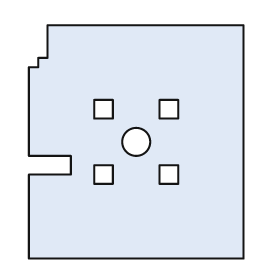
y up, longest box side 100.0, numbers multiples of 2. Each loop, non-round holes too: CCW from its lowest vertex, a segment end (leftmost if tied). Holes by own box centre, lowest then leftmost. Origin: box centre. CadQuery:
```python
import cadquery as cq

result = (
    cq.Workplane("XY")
    .moveTo(-46.0, -50.0)
    .lineTo(46.0, -50.0)
    .lineTo(46.0, 50.0)
    .lineTo(-38.0, 50.0)
    .lineTo(-38.0, 36.0)
    .lineTo(-42.0, 36.0)
    .lineTo(-42.0, 32.0)
    .lineTo(-46.0, 32.0)
    .lineTo(-46.0, -6.0)
    .lineTo(-28.0, -6.0)
    .lineTo(-28.0, -14.0)
    .lineTo(-46.0, -14.0)
    .close()
    .moveTo(-18.0, -18.0)
    .lineTo(-10.0, -18.0)
    .lineTo(-10.0, -10.0)
    .lineTo(-18.0, -10.0)
    .close()
    .moveTo(10.0, -18.0)
    .lineTo(18.0, -18.0)
    .lineTo(18.0, -10.0)
    .lineTo(10.0, -10.0)
    .close()
    .moveTo(0.0, 0.0)
    .circle(6.0)
    .moveTo(-18.0, 10.0)
    .lineTo(-10.0, 10.0)
    .lineTo(-10.0, 18.0)
    .lineTo(-18.0, 18.0)
    .close()
    .moveTo(10.0, 10.0)
    .lineTo(18.0, 10.0)
    .lineTo(18.0, 18.0)
    .lineTo(10.0, 18.0)
    .close()
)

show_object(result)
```